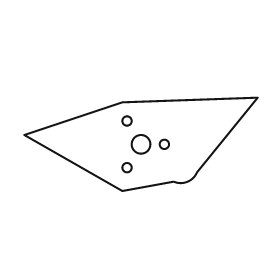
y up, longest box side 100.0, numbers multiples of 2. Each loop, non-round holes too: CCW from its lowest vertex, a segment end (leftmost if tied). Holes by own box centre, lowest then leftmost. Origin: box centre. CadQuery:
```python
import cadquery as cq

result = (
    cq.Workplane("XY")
    .moveTo(-8.0, -20.0)
    .lineTo(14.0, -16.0)
    .threePointArc((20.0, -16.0), (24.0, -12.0))
    .lineTo(50.0, 20.0)
    .lineTo(-8.0, 18.0)
    .lineTo(-50.0, 4.0)
    .close()
    .moveTo(-6.0, -10.0)
    .circle(2.0)
    .moveTo(0.0, 0.0)
    .circle(4.0)
    .moveTo(10.0, 0.0)
    .circle(2.0)
    .moveTo(-6.0, 10.0)
    .circle(2.0)
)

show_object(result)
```